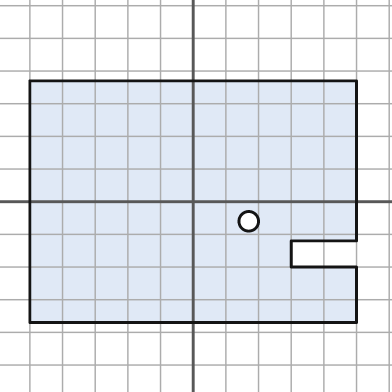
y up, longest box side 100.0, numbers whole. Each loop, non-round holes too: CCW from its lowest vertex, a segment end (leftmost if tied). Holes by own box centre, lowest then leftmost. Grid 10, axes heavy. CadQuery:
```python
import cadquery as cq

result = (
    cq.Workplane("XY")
    .moveTo(-50.0, -37.0)
    .lineTo(50.0, -37.0)
    .lineTo(50.0, -20.0)
    .lineTo(30.0, -20.0)
    .lineTo(30.0, -12.0)
    .lineTo(50.0, -12.0)
    .lineTo(50.0, 37.0)
    .lineTo(-50.0, 37.0)
    .close()
    .moveTo(17.0, -6.0)
    .circle(3.0)
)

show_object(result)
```